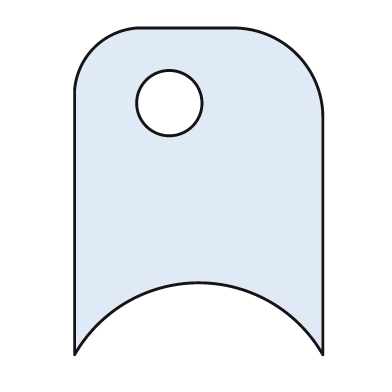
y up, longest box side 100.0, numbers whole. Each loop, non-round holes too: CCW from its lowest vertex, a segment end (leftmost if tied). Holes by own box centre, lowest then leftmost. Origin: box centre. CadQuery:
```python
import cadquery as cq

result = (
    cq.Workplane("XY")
    .moveTo(-38.0, -50.0)
    .threePointArc((0.0, -28.0), (38.0, -50.0))
    .lineTo(38.0, 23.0)
    .threePointArc((30.0, 42.0), (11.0, 50.0))
    .lineTo(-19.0, 50.0)
    .threePointArc((-32.0, 44.0), (-38.0, 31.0))
    .close()
    .moveTo(-9.0, 27.0)
    .circle(10.0)
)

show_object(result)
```